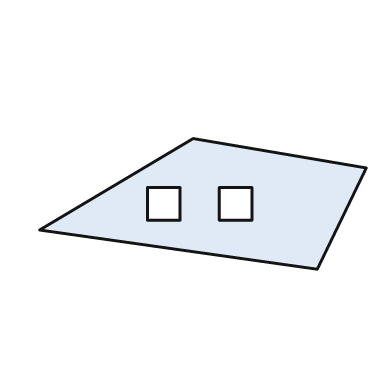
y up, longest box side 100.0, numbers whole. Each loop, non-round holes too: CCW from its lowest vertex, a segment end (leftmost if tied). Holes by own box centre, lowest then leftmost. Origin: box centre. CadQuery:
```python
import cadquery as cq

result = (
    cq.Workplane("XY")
    .moveTo(35.0, -20.0)
    .lineTo(50.0, 11.0)
    .lineTo(-3.0, 20.0)
    .lineTo(-50.0, -8.0)
    .close()
    .moveTo(-17.0, -5.0)
    .lineTo(-7.0, -5.0)
    .lineTo(-7.0, 5.0)
    .lineTo(-17.0, 5.0)
    .close()
    .moveTo(5.0, -5.0)
    .lineTo(15.0, -5.0)
    .lineTo(15.0, 5.0)
    .lineTo(5.0, 5.0)
    .close()
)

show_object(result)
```